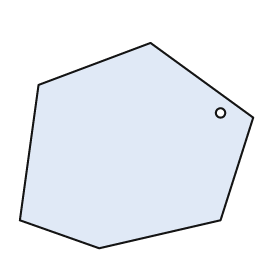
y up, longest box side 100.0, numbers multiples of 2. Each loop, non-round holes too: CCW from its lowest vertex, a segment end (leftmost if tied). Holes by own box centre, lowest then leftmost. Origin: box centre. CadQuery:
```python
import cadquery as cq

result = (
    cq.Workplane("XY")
    .moveTo(-16.0, -44.0)
    .lineTo(36.0, -32.0)
    .lineTo(50.0, 12.0)
    .lineTo(6.0, 44.0)
    .lineTo(-42.0, 26.0)
    .lineTo(-50.0, -32.0)
    .close()
    .moveTo(36.0, 14.0)
    .circle(2.0)
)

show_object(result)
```